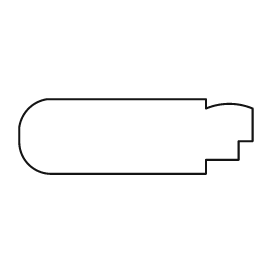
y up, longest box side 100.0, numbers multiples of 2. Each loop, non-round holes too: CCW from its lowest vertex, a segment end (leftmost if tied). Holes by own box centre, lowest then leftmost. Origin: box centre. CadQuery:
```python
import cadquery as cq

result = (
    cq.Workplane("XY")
    .moveTo(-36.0, -16.0)
    .lineTo(30.0, -16.0)
    .lineTo(30.0, -10.0)
    .lineTo(44.0, -10.0)
    .lineTo(44.0, -2.0)
    .lineTo(50.0, -2.0)
    .lineTo(50.0, 12.0)
    .threePointArc((40.0, 14.0), (30.0, 12.0))
    .lineTo(30.0, 16.0)
    .lineTo(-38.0, 16.0)
    .threePointArc((-46.0, 12.0), (-50.0, 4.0))
    .lineTo(-50.0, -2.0)
    .threePointArc((-46.0, -12.0), (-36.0, -16.0))
    .close()
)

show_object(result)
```